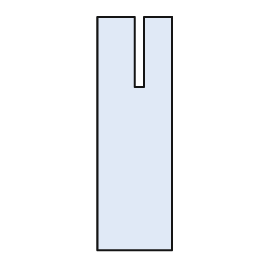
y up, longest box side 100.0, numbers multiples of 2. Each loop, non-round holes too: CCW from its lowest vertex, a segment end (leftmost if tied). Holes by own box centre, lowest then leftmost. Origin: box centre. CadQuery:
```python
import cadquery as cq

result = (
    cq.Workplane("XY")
    .moveTo(-16.0, -50.0)
    .lineTo(16.0, -50.0)
    .lineTo(16.0, 50.0)
    .lineTo(4.0, 50.0)
    .lineTo(4.0, 20.0)
    .lineTo(0.0, 20.0)
    .lineTo(0.0, 50.0)
    .lineTo(-16.0, 50.0)
    .close()
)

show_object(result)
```